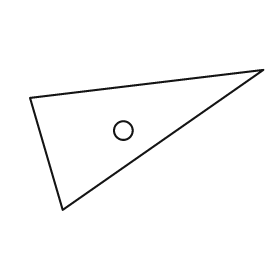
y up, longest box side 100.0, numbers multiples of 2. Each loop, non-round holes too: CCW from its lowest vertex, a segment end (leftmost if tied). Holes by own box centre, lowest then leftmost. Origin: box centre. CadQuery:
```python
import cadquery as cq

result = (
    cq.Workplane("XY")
    .moveTo(-36.0, -30.0)
    .lineTo(50.0, 30.0)
    .lineTo(-50.0, 18.0)
    .close()
    .moveTo(-10.0, 4.0)
    .circle(4.0)
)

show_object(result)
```